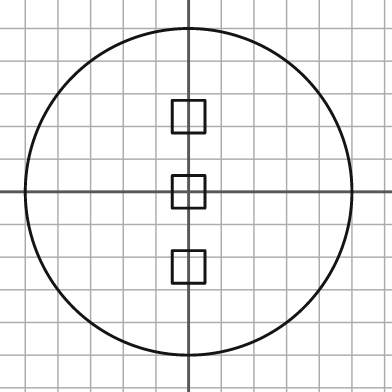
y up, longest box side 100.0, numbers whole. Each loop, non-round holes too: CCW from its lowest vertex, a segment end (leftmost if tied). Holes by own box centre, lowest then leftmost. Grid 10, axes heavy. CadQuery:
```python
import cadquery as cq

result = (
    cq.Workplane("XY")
    .moveTo(0.0, 0.0)
    .circle(50.0)
    .moveTo(-5.0, -28.0)
    .lineTo(5.0, -28.0)
    .lineTo(5.0, -18.0)
    .lineTo(-5.0, -18.0)
    .close()
    .moveTo(-5.0, -5.0)
    .lineTo(5.0, -5.0)
    .lineTo(5.0, 5.0)
    .lineTo(-5.0, 5.0)
    .close()
    .moveTo(-5.0, 18.0)
    .lineTo(5.0, 18.0)
    .lineTo(5.0, 28.0)
    .lineTo(-5.0, 28.0)
    .close()
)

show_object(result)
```